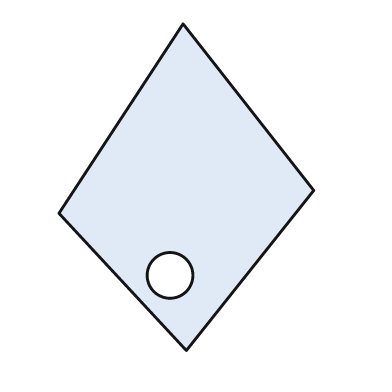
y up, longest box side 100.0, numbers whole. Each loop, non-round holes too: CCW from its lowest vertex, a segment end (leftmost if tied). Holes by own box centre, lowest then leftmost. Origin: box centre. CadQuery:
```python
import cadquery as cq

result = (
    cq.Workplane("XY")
    .moveTo(0.0, -50.0)
    .lineTo(39.0, -1.0)
    .lineTo(-1.0, 50.0)
    .lineTo(-39.0, -8.0)
    .close()
    .moveTo(-5.0, -27.0)
    .circle(7.0)
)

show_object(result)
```